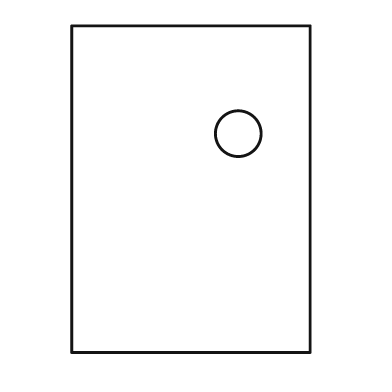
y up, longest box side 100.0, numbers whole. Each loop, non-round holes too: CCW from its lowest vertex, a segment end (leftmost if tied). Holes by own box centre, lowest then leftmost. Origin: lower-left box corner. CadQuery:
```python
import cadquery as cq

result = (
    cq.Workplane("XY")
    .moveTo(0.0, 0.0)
    .lineTo(73.0, 0.0)
    .lineTo(73.0, 100.0)
    .lineTo(0.0, 100.0)
    .close()
    .moveTo(51.0, 67.0)
    .circle(7.0)
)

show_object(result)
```